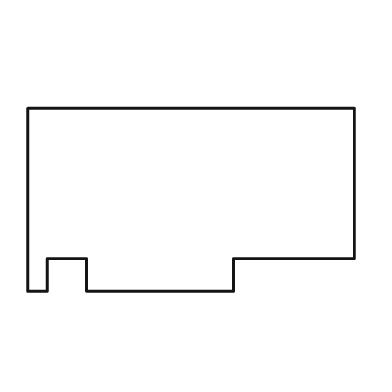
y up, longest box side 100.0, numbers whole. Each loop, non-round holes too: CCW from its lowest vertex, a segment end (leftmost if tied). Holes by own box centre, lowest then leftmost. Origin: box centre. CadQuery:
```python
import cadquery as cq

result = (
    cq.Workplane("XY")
    .moveTo(-50.0, -28.0)
    .lineTo(-44.0, -28.0)
    .lineTo(-44.0, -18.0)
    .lineTo(-32.0, -18.0)
    .lineTo(-32.0, -28.0)
    .lineTo(13.0, -28.0)
    .lineTo(13.0, -18.0)
    .lineTo(50.0, -18.0)
    .lineTo(50.0, 28.0)
    .lineTo(-50.0, 28.0)
    .close()
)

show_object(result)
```